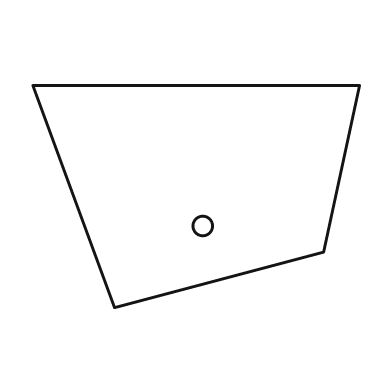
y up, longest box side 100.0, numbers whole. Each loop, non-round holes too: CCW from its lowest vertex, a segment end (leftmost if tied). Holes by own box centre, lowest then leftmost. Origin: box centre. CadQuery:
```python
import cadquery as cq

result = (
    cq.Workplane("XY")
    .moveTo(-25.0, -34.0)
    .lineTo(39.0, -17.0)
    .lineTo(50.0, 34.0)
    .lineTo(-50.0, 34.0)
    .close()
    .moveTo(2.0, -9.0)
    .circle(3.0)
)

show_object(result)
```